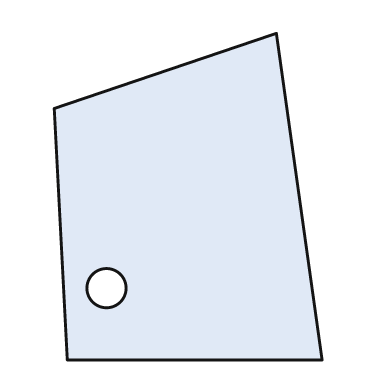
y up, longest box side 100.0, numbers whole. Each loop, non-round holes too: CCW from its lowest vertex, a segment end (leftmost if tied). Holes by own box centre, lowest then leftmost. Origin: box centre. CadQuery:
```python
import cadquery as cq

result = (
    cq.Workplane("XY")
    .moveTo(-37.0, -50.0)
    .lineTo(41.0, -50.0)
    .lineTo(27.0, 50.0)
    .lineTo(-41.0, 27.0)
    .close()
    .moveTo(-25.0, -28.0)
    .circle(6.0)
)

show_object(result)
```